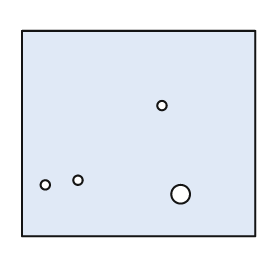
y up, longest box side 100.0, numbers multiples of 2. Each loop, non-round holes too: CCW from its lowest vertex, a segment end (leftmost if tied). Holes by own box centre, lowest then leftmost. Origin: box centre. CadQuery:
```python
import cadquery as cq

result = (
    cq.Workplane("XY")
    .moveTo(-50.0, -44.0)
    .lineTo(50.0, -44.0)
    .lineTo(50.0, 44.0)
    .lineTo(-50.0, 44.0)
    .close()
    .moveTo(18.0, -26.0)
    .circle(4.0)
    .moveTo(-40.0, -22.0)
    .circle(2.0)
    .moveTo(-26.0, -20.0)
    .circle(2.0)
    .moveTo(10.0, 12.0)
    .circle(2.0)
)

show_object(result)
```